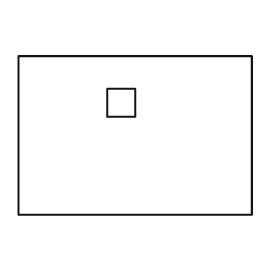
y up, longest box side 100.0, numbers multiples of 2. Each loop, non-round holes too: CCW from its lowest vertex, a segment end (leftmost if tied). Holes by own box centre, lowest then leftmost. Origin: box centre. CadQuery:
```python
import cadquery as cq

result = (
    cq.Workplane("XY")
    .moveTo(-50.0, -34.0)
    .lineTo(50.0, -34.0)
    .lineTo(50.0, 34.0)
    .lineTo(-50.0, 34.0)
    .close()
    .moveTo(-12.0, 8.0)
    .lineTo(0.0, 8.0)
    .lineTo(0.0, 20.0)
    .lineTo(-12.0, 20.0)
    .close()
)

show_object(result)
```